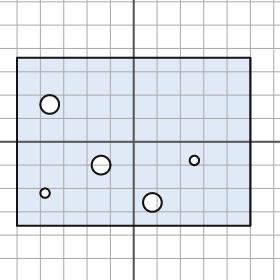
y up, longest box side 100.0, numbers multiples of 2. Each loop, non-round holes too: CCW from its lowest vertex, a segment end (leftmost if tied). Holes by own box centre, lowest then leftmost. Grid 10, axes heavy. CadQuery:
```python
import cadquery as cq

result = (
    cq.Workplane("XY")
    .moveTo(-50.0, -36.0)
    .lineTo(50.0, -36.0)
    .lineTo(50.0, 36.0)
    .lineTo(-50.0, 36.0)
    .close()
    .moveTo(8.0, -26.0)
    .circle(4.0)
    .moveTo(-38.0, -22.0)
    .circle(2.0)
    .moveTo(-14.0, -10.0)
    .circle(4.0)
    .moveTo(26.0, -8.0)
    .circle(2.0)
    .moveTo(-36.0, 16.0)
    .circle(4.0)
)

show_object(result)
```